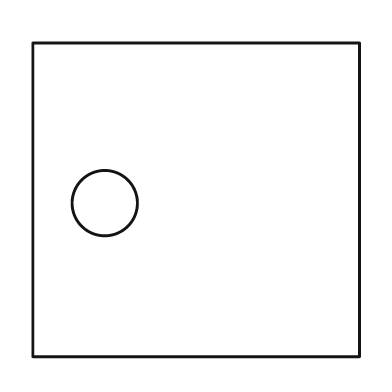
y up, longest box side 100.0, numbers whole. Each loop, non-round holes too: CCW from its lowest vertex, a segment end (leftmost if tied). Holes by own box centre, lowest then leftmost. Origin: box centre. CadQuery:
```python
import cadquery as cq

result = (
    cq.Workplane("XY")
    .moveTo(-50.0, -48.0)
    .lineTo(50.0, -48.0)
    .lineTo(50.0, 48.0)
    .lineTo(-50.0, 48.0)
    .close()
    .moveTo(-28.0, -1.0)
    .circle(10.0)
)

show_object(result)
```